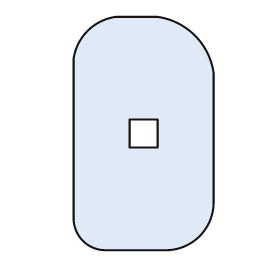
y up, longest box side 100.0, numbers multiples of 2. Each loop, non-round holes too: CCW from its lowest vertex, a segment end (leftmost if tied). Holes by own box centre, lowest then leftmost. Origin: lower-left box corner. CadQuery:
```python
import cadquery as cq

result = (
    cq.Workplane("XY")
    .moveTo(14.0, 0.0)
    .lineTo(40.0, 0.0)
    .threePointArc((54.0, 6.0), (60.0, 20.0))
    .lineTo(60.0, 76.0)
    .threePointArc((52.0, 92.0), (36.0, 100.0))
    .lineTo(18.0, 100.0)
    .threePointArc((6.0, 94.0), (0.0, 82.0))
    .lineTo(0.0, 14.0)
    .threePointArc((4.0, 4.0), (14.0, 0.0))
    .close()
    .moveTo(24.0, 44.0)
    .lineTo(36.0, 44.0)
    .lineTo(36.0, 56.0)
    .lineTo(24.0, 56.0)
    .close()
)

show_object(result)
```